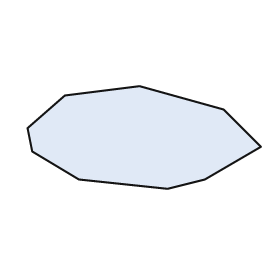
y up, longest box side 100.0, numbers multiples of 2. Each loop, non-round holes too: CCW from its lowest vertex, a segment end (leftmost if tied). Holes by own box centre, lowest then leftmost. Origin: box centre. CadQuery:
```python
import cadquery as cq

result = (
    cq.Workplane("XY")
    .moveTo(10.0, -22.0)
    .lineTo(26.0, -18.0)
    .lineTo(50.0, -4.0)
    .lineTo(34.0, 12.0)
    .lineTo(-2.0, 22.0)
    .lineTo(-34.0, 18.0)
    .lineTo(-50.0, 4.0)
    .lineTo(-48.0, -6.0)
    .lineTo(-28.0, -18.0)
    .close()
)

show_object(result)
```